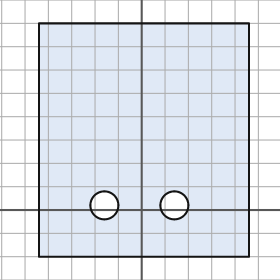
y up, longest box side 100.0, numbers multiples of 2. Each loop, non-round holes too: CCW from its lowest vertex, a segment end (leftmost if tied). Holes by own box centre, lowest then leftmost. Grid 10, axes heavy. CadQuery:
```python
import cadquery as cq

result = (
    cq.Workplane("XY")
    .moveTo(-44.0, -20.0)
    .lineTo(46.0, -20.0)
    .lineTo(46.0, 80.0)
    .lineTo(-44.0, 80.0)
    .close()
    .moveTo(-16.0, 2.0)
    .circle(6.0)
    .moveTo(14.0, 2.0)
    .circle(6.0)
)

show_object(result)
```